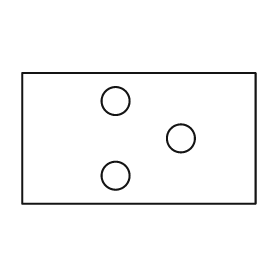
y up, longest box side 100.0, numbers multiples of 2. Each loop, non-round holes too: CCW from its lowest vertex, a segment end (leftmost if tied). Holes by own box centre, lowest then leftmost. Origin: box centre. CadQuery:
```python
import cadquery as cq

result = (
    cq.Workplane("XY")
    .moveTo(-50.0, -28.0)
    .lineTo(50.0, -28.0)
    .lineTo(50.0, 28.0)
    .lineTo(-50.0, 28.0)
    .close()
    .moveTo(-10.0, -16.0)
    .circle(6.0)
    .moveTo(18.0, 0.0)
    .circle(6.0)
    .moveTo(-10.0, 16.0)
    .circle(6.0)
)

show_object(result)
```